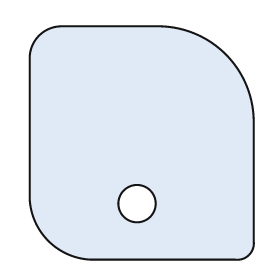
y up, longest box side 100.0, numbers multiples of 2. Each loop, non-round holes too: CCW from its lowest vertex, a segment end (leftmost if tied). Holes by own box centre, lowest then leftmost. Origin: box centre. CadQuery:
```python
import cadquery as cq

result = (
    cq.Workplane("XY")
    .moveTo(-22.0, -50.0)
    .lineTo(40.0, -50.0)
    .threePointArc((46.0, -48.0), (48.0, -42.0))
    .lineTo(48.0, 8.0)
    .threePointArc((36.0, 38.0), (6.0, 50.0))
    .lineTo(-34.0, 50.0)
    .threePointArc((-44.0, 46.0), (-48.0, 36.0))
    .lineTo(-48.0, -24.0)
    .threePointArc((-40.0, -42.0), (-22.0, -50.0))
    .close()
    .moveTo(-2.0, -26.0)
    .circle(8.0)
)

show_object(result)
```